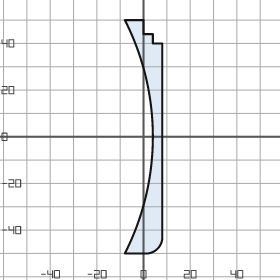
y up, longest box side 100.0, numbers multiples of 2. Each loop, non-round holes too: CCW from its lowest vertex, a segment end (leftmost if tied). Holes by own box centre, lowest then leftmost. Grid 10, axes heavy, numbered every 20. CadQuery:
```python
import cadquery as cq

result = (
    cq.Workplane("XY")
    .moveTo(-8.0, -50.0)
    .lineTo(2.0, -50.0)
    .threePointArc((6.0, -48.0), (8.0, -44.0))
    .lineTo(8.0, 40.0)
    .lineTo(4.0, 40.0)
    .lineTo(4.0, 44.0)
    .lineTo(0.0, 44.0)
    .lineTo(0.0, 50.0)
    .lineTo(-8.0, 50.0)
    .threePointArc((4.0, 0.0), (-8.0, -50.0))
    .close()
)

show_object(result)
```